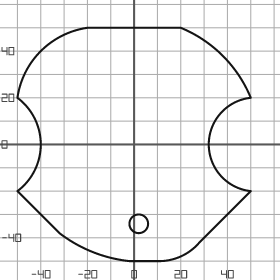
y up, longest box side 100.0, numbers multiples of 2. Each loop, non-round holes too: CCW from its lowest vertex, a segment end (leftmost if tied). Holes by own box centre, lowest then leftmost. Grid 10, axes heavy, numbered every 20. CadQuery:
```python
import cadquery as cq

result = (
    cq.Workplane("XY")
    .moveTo(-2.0, -50.0)
    .lineTo(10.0, -50.0)
    .threePointArc((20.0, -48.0), (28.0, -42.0))
    .lineTo(50.0, -20.0)
    .threePointArc((32.0, 0.0), (50.0, 20.0))
    .threePointArc((38.0, 38.0), (20.0, 50.0))
    .lineTo(-20.0, 50.0)
    .threePointArc((-40.0, 40.0), (-50.0, 20.0))
    .threePointArc((-40.0, 0.0), (-50.0, -20.0))
    .lineTo(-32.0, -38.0)
    .threePointArc((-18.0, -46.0), (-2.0, -50.0))
    .close()
    .moveTo(2.0, -34.0)
    .circle(4.0)
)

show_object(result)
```